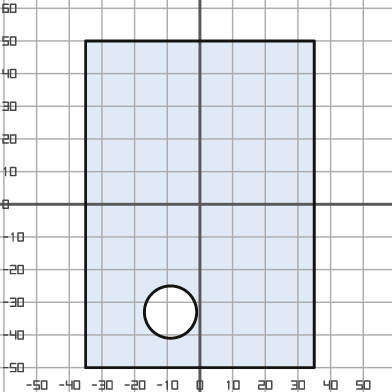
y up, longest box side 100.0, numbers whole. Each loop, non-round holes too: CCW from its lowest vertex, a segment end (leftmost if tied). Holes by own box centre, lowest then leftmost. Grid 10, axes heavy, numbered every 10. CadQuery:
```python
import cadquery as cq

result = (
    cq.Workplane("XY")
    .moveTo(-35.0, -50.0)
    .lineTo(35.0, -50.0)
    .lineTo(35.0, 50.0)
    .lineTo(-35.0, 50.0)
    .close()
    .moveTo(-9.0, -33.0)
    .circle(8.0)
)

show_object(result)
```